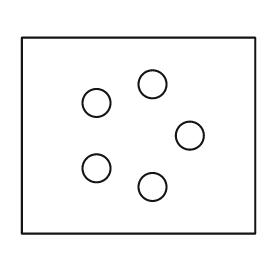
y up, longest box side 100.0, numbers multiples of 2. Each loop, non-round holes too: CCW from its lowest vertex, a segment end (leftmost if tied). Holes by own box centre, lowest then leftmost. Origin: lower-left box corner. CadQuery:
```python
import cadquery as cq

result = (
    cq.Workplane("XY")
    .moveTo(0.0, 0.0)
    .lineTo(100.0, 0.0)
    .lineTo(100.0, 84.0)
    .lineTo(0.0, 84.0)
    .close()
    .moveTo(56.0, 20.0)
    .circle(6.0)
    .moveTo(32.0, 28.0)
    .circle(6.0)
    .moveTo(72.0, 42.0)
    .circle(6.0)
    .moveTo(32.0, 56.0)
    .circle(6.0)
    .moveTo(56.0, 64.0)
    .circle(6.0)
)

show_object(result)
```